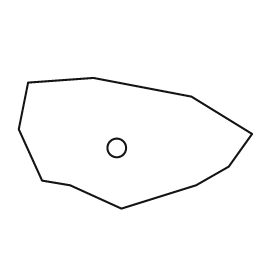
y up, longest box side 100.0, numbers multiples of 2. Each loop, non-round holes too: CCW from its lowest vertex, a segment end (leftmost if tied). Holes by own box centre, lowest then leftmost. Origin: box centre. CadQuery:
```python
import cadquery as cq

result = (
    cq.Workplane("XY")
    .moveTo(-6.0, -28.0)
    .lineTo(26.0, -18.0)
    .lineTo(40.0, -10.0)
    .lineTo(50.0, 4.0)
    .lineTo(24.0, 20.0)
    .lineTo(-18.0, 28.0)
    .lineTo(-46.0, 26.0)
    .lineTo(-50.0, 6.0)
    .lineTo(-40.0, -16.0)
    .lineTo(-28.0, -18.0)
    .close()
    .moveTo(-8.0, -2.0)
    .circle(4.0)
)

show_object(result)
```